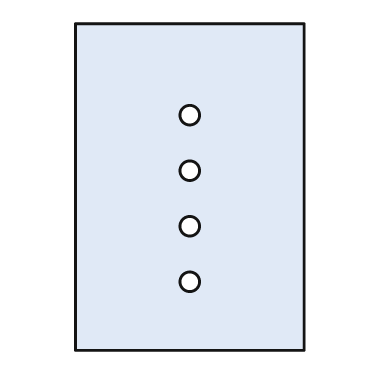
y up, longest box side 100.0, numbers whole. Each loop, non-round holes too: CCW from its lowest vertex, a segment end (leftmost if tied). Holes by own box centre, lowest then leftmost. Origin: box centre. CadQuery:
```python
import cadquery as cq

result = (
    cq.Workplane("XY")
    .moveTo(-35.0, -50.0)
    .lineTo(35.0, -50.0)
    .lineTo(35.0, 50.0)
    .lineTo(-35.0, 50.0)
    .close()
    .moveTo(0.0, -29.0)
    .circle(3.0)
    .moveTo(0.0, -12.0)
    .circle(3.0)
    .moveTo(0.0, 5.0)
    .circle(3.0)
    .moveTo(0.0, 22.0)
    .circle(3.0)
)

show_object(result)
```